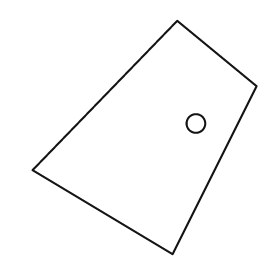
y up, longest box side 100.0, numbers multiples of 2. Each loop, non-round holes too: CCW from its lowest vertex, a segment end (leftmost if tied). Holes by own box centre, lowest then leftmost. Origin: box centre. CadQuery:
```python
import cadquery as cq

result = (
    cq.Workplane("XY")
    .moveTo(12.0, -50.0)
    .lineTo(48.0, 22.0)
    .lineTo(14.0, 50.0)
    .lineTo(-48.0, -14.0)
    .close()
    .moveTo(22.0, 6.0)
    .circle(4.0)
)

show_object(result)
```